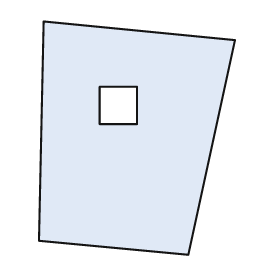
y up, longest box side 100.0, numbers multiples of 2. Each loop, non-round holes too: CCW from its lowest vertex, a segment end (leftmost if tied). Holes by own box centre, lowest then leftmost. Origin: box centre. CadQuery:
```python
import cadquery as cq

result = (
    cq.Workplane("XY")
    .moveTo(22.0, -50.0)
    .lineTo(42.0, 42.0)
    .lineTo(-40.0, 50.0)
    .lineTo(-42.0, -44.0)
    .close()
    .moveTo(-16.0, 6.0)
    .lineTo(0.0, 6.0)
    .lineTo(0.0, 22.0)
    .lineTo(-16.0, 22.0)
    .close()
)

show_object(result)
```